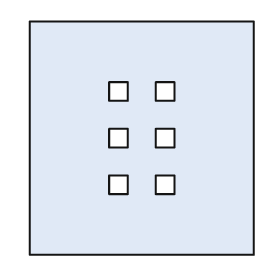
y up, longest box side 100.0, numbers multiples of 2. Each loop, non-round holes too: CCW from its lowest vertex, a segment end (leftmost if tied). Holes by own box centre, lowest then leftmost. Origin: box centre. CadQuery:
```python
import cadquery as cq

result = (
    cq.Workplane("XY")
    .moveTo(-48.0, -50.0)
    .lineTo(48.0, -50.0)
    .lineTo(48.0, 50.0)
    .lineTo(-48.0, 50.0)
    .close()
    .moveTo(-14.0, -24.0)
    .lineTo(-6.0, -24.0)
    .lineTo(-6.0, -16.0)
    .lineTo(-14.0, -16.0)
    .close()
    .moveTo(6.0, -24.0)
    .lineTo(14.0, -24.0)
    .lineTo(14.0, -16.0)
    .lineTo(6.0, -16.0)
    .close()
    .moveTo(-14.0, -4.0)
    .lineTo(-6.0, -4.0)
    .lineTo(-6.0, 4.0)
    .lineTo(-14.0, 4.0)
    .close()
    .moveTo(6.0, -4.0)
    .lineTo(14.0, -4.0)
    .lineTo(14.0, 4.0)
    .lineTo(6.0, 4.0)
    .close()
    .moveTo(-14.0, 16.0)
    .lineTo(-6.0, 16.0)
    .lineTo(-6.0, 24.0)
    .lineTo(-14.0, 24.0)
    .close()
    .moveTo(6.0, 16.0)
    .lineTo(14.0, 16.0)
    .lineTo(14.0, 24.0)
    .lineTo(6.0, 24.0)
    .close()
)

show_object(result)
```